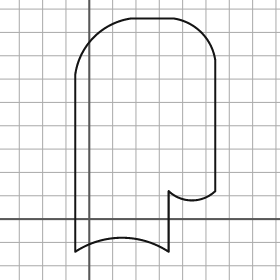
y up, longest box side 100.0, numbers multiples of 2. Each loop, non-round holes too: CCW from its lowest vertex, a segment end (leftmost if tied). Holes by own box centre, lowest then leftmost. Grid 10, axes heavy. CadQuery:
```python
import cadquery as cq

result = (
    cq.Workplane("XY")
    .moveTo(-6.0, -14.0)
    .threePointArc((14.0, -8.0), (34.0, -14.0))
    .lineTo(34.0, 12.0)
    .threePointArc((44.0, 8.0), (54.0, 12.0))
    .lineTo(54.0, 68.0)
    .threePointArc((48.0, 80.0), (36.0, 86.0))
    .lineTo(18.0, 86.0)
    .threePointArc((2.0, 78.0), (-6.0, 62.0))
    .close()
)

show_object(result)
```